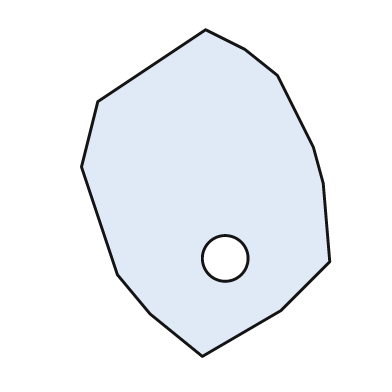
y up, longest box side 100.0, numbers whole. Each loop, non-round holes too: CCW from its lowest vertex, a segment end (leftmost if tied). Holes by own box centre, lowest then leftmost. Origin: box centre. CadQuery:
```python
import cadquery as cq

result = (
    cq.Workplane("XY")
    .moveTo(-1.0, -50.0)
    .lineTo(23.0, -36.0)
    .lineTo(38.0, -21.0)
    .lineTo(36.0, 3.0)
    .lineTo(33.0, 14.0)
    .lineTo(22.0, 36.0)
    .lineTo(12.0, 44.0)
    .lineTo(0.0, 50.0)
    .lineTo(-33.0, 28.0)
    .lineTo(-38.0, 8.0)
    .lineTo(-27.0, -25.0)
    .lineTo(-17.0, -37.0)
    .close()
    .moveTo(6.0, -20.0)
    .circle(7.0)
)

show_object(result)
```